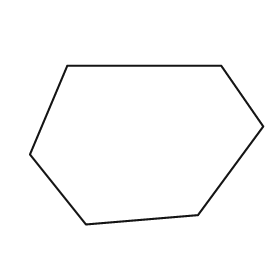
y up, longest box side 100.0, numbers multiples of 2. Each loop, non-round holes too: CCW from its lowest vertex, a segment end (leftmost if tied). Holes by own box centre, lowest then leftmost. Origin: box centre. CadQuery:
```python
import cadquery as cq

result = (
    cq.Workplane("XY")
    .moveTo(-26.0, -34.0)
    .lineTo(22.0, -30.0)
    .lineTo(50.0, 8.0)
    .lineTo(32.0, 34.0)
    .lineTo(-34.0, 34.0)
    .lineTo(-50.0, -4.0)
    .close()
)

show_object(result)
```